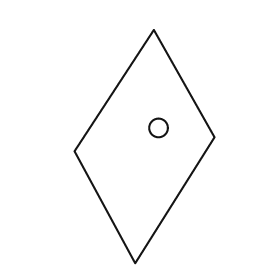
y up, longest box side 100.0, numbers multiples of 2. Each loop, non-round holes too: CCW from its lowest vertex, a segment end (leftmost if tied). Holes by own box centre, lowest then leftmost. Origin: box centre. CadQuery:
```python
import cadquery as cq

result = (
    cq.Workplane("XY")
    .moveTo(-4.0, -50.0)
    .lineTo(30.0, 4.0)
    .lineTo(4.0, 50.0)
    .lineTo(-30.0, -2.0)
    .close()
    .moveTo(6.0, 8.0)
    .circle(4.0)
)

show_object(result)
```